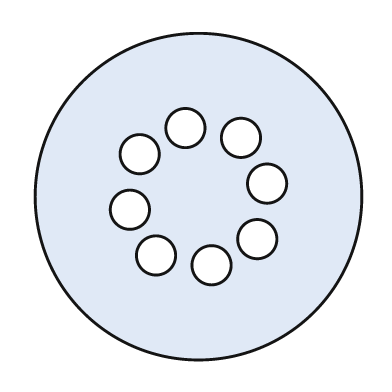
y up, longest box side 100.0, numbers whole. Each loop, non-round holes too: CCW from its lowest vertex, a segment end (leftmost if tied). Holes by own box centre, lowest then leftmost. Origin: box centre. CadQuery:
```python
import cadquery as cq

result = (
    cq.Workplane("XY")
    .moveTo(0.0, 0.0)
    .circle(50.0)
    .moveTo(4.0, -21.0)
    .circle(6.0)
    .moveTo(-13.0, -18.0)
    .circle(6.0)
    .moveTo(18.0, -13.0)
    .circle(6.0)
    .moveTo(-21.0, -4.0)
    .circle(6.0)
    .moveTo(21.0, 4.0)
    .circle(6.0)
    .moveTo(-18.0, 13.0)
    .circle(6.0)
    .moveTo(13.0, 18.0)
    .circle(6.0)
    .moveTo(-4.0, 21.0)
    .circle(6.0)
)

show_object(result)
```